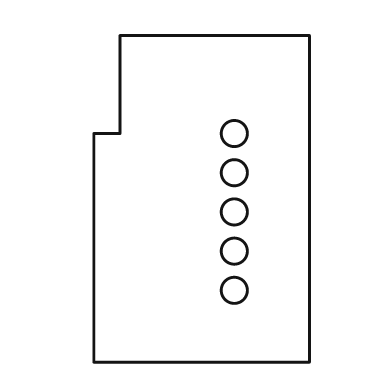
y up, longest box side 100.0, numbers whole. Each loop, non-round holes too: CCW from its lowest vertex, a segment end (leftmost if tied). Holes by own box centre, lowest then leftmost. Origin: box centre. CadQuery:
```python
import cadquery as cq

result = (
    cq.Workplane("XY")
    .moveTo(-33.0, -50.0)
    .lineTo(33.0, -50.0)
    .lineTo(33.0, 50.0)
    .lineTo(-25.0, 50.0)
    .lineTo(-25.0, 20.0)
    .lineTo(-33.0, 20.0)
    .close()
    .moveTo(10.0, -28.0)
    .circle(4.0)
    .moveTo(10.0, -16.0)
    .circle(4.0)
    .moveTo(10.0, -4.0)
    .circle(4.0)
    .moveTo(10.0, 8.0)
    .circle(4.0)
    .moveTo(10.0, 20.0)
    .circle(4.0)
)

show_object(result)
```